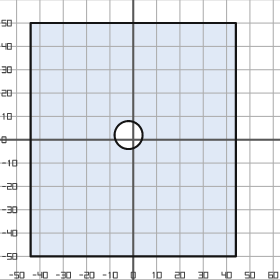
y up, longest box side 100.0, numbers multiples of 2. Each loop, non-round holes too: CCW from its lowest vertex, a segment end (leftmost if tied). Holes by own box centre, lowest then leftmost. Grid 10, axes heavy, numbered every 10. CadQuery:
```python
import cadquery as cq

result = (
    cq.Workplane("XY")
    .moveTo(-44.0, -50.0)
    .lineTo(44.0, -50.0)
    .lineTo(44.0, 50.0)
    .lineTo(-44.0, 50.0)
    .close()
    .moveTo(-2.0, 2.0)
    .circle(6.0)
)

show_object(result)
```